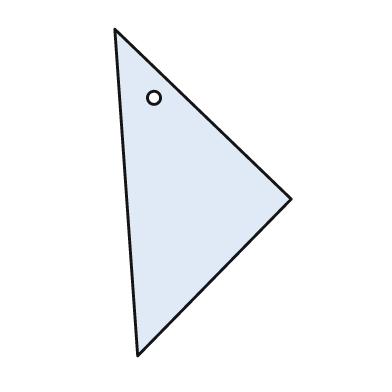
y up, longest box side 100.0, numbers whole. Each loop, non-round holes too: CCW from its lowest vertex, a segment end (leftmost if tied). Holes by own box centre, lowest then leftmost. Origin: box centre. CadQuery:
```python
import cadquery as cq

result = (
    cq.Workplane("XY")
    .moveTo(-20.0, -50.0)
    .lineTo(27.0, -2.0)
    .lineTo(-27.0, 50.0)
    .close()
    .moveTo(-15.0, 29.0)
    .circle(2.0)
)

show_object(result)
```